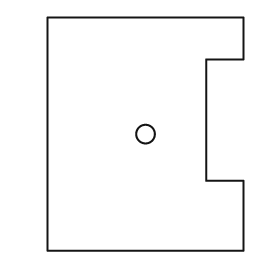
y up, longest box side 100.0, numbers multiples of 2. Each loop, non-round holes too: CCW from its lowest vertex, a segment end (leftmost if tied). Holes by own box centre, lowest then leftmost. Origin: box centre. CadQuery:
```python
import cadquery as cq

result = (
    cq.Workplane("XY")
    .moveTo(-42.0, -50.0)
    .lineTo(42.0, -50.0)
    .lineTo(42.0, -20.0)
    .lineTo(26.0, -20.0)
    .lineTo(26.0, 32.0)
    .lineTo(42.0, 32.0)
    .lineTo(42.0, 50.0)
    .lineTo(-42.0, 50.0)
    .close()
    .moveTo(0.0, 0.0)
    .circle(4.0)
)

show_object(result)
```